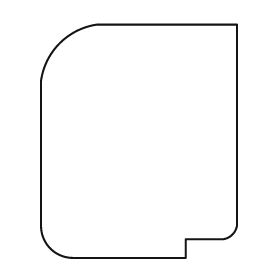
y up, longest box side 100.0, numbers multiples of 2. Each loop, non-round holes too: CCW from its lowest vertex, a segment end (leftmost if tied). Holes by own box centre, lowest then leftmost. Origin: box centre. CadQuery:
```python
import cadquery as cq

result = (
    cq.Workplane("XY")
    .moveTo(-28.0, -50.0)
    .lineTo(20.0, -50.0)
    .lineTo(20.0, -42.0)
    .lineTo(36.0, -42.0)
    .threePointArc((40.0, -40.0), (42.0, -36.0))
    .lineTo(42.0, 50.0)
    .lineTo(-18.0, 50.0)
    .threePointArc((-34.0, 42.0), (-42.0, 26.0))
    .lineTo(-42.0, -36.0)
    .threePointArc((-38.0, -46.0), (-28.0, -50.0))
    .close()
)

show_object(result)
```